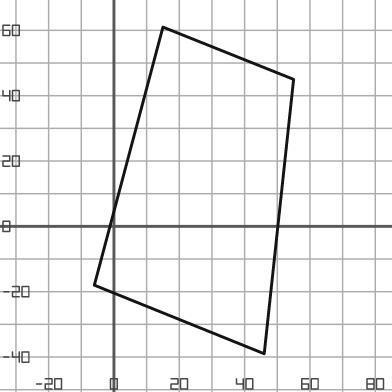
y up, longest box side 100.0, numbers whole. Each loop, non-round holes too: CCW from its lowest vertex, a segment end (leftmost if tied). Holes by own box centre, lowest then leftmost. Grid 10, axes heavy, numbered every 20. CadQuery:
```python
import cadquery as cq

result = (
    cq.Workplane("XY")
    .moveTo(46.0, -39.0)
    .lineTo(55.0, 45.0)
    .lineTo(15.0, 61.0)
    .lineTo(-6.0, -18.0)
    .close()
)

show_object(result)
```